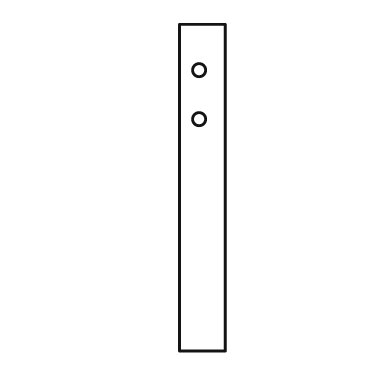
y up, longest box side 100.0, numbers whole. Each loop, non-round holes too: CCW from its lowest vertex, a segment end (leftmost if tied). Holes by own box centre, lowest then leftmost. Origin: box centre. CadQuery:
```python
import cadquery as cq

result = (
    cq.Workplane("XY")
    .moveTo(-7.0, -50.0)
    .lineTo(7.0, -50.0)
    .lineTo(7.0, 50.0)
    .lineTo(-7.0, 50.0)
    .close()
    .moveTo(-1.0, 21.0)
    .circle(2.0)
    .moveTo(-1.0, 36.0)
    .circle(2.0)
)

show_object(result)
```